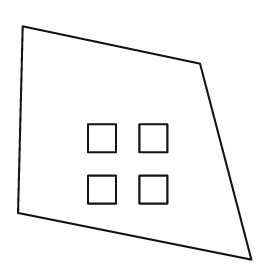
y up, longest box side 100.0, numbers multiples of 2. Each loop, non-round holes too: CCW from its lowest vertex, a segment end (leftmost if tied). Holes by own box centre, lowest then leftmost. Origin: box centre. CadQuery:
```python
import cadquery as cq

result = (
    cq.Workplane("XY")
    .moveTo(50.0, -50.0)
    .lineTo(28.0, 34.0)
    .lineTo(-48.0, 50.0)
    .lineTo(-50.0, -30.0)
    .close()
    .moveTo(-20.0, -26.0)
    .lineTo(-8.0, -26.0)
    .lineTo(-8.0, -14.0)
    .lineTo(-20.0, -14.0)
    .close()
    .moveTo(2.0, -26.0)
    .lineTo(14.0, -26.0)
    .lineTo(14.0, -14.0)
    .lineTo(2.0, -14.0)
    .close()
    .moveTo(-20.0, -4.0)
    .lineTo(-8.0, -4.0)
    .lineTo(-8.0, 8.0)
    .lineTo(-20.0, 8.0)
    .close()
    .moveTo(2.0, -4.0)
    .lineTo(14.0, -4.0)
    .lineTo(14.0, 8.0)
    .lineTo(2.0, 8.0)
    .close()
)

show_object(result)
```